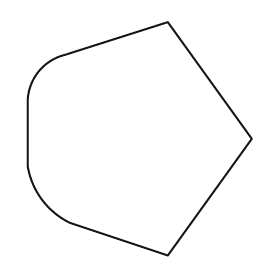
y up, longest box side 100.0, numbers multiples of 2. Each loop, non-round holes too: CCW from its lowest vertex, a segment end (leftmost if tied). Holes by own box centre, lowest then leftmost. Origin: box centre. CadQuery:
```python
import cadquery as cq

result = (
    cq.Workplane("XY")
    .moveTo(12.0, -50.0)
    .lineTo(48.0, 0.0)
    .lineTo(12.0, 50.0)
    .lineTo(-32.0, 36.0)
    .threePointArc((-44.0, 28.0), (-48.0, 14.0))
    .lineTo(-48.0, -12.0)
    .threePointArc((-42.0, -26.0), (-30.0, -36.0))
    .close()
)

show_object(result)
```